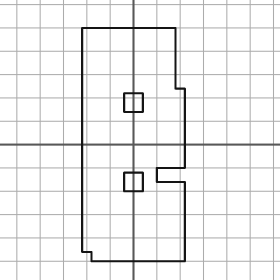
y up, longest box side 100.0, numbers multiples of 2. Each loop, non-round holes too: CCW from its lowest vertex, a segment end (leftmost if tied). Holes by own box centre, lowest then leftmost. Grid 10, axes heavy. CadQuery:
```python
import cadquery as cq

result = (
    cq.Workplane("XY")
    .moveTo(-18.0, -50.0)
    .lineTo(22.0, -50.0)
    .lineTo(22.0, -16.0)
    .lineTo(10.0, -16.0)
    .lineTo(10.0, -10.0)
    .lineTo(22.0, -10.0)
    .lineTo(22.0, 24.0)
    .lineTo(18.0, 24.0)
    .lineTo(18.0, 50.0)
    .lineTo(-22.0, 50.0)
    .lineTo(-22.0, -46.0)
    .lineTo(-18.0, -46.0)
    .close()
    .moveTo(-4.0, -20.0)
    .lineTo(4.0, -20.0)
    .lineTo(4.0, -12.0)
    .lineTo(-4.0, -12.0)
    .close()
    .moveTo(-4.0, 14.0)
    .lineTo(4.0, 14.0)
    .lineTo(4.0, 22.0)
    .lineTo(-4.0, 22.0)
    .close()
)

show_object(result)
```